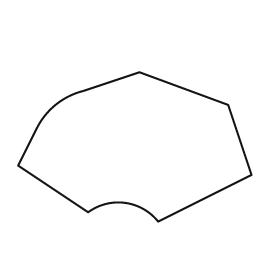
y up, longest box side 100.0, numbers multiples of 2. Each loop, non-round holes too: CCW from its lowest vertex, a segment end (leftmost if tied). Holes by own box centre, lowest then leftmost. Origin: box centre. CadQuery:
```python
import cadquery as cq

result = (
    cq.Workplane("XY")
    .moveTo(10.0, -32.0)
    .lineTo(50.0, -12.0)
    .lineTo(40.0, 18.0)
    .lineTo(2.0, 32.0)
    .lineTo(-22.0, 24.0)
    .threePointArc((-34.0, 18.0), (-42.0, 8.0))
    .lineTo(-50.0, -8.0)
    .lineTo(-20.0, -28.0)
    .threePointArc((-4.0, -24.0), (10.0, -32.0))
    .close()
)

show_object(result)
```